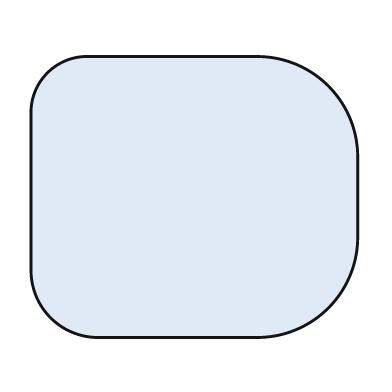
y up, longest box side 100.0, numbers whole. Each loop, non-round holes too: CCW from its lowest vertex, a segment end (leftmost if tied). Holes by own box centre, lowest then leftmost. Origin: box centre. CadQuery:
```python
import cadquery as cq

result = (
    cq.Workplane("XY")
    .moveTo(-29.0, -43.0)
    .lineTo(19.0, -43.0)
    .threePointArc((41.0, -34.0), (50.0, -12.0))
    .lineTo(50.0, 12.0)
    .threePointArc((41.0, 34.0), (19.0, 43.0))
    .lineTo(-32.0, 43.0)
    .threePointArc((-45.0, 38.0), (-50.0, 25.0))
    .lineTo(-50.0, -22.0)
    .threePointArc((-44.0, -37.0), (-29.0, -43.0))
    .close()
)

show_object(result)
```